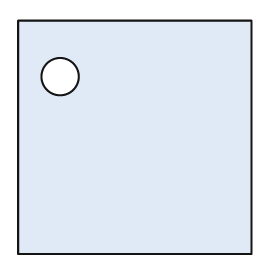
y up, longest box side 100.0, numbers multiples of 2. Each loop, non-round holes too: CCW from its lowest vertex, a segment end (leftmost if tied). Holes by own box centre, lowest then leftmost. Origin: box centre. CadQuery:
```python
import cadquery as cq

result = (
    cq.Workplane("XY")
    .moveTo(-50.0, -50.0)
    .lineTo(50.0, -50.0)
    .lineTo(50.0, 50.0)
    .lineTo(-50.0, 50.0)
    .close()
    .moveTo(-32.0, 26.0)
    .circle(8.0)
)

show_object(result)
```